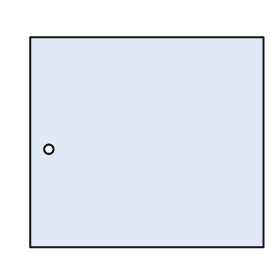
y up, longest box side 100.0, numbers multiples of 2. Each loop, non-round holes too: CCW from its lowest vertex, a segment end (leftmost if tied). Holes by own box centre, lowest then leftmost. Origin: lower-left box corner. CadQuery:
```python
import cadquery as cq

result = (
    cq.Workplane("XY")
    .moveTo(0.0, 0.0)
    .lineTo(100.0, 0.0)
    .lineTo(100.0, 90.0)
    .lineTo(0.0, 90.0)
    .close()
    .moveTo(8.0, 42.0)
    .circle(2.0)
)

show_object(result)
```